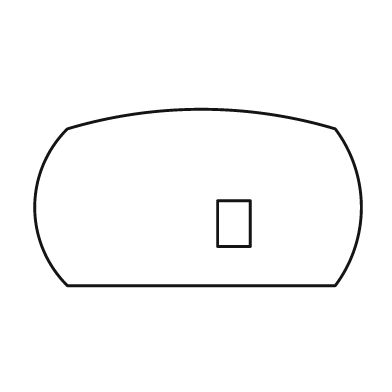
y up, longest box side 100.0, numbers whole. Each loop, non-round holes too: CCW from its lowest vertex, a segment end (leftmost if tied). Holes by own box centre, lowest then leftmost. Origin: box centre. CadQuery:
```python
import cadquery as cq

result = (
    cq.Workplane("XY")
    .moveTo(-40.0, -27.0)
    .lineTo(42.0, -27.0)
    .threePointArc((50.0, -3.0), (42.0, 21.0))
    .threePointArc((1.0, 27.0), (-40.0, 21.0))
    .threePointArc((-50.0, -3.0), (-40.0, -27.0))
    .close()
    .moveTo(6.0, -15.0)
    .lineTo(16.0, -15.0)
    .lineTo(16.0, -1.0)
    .lineTo(6.0, -1.0)
    .close()
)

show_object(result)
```